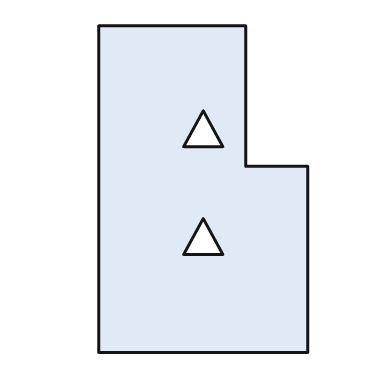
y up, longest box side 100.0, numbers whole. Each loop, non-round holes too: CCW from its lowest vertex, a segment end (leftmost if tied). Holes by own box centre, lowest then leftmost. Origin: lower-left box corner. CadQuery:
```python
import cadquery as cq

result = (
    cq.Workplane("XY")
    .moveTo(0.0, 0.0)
    .lineTo(64.0, 0.0)
    .lineTo(64.0, 57.0)
    .lineTo(45.0, 57.0)
    .lineTo(45.0, 100.0)
    .lineTo(0.0, 100.0)
    .close()
    .moveTo(26.0, 30.0)
    .lineTo(38.0, 30.0)
    .lineTo(32.0, 41.0)
    .close()
    .moveTo(26.0, 63.0)
    .lineTo(38.0, 63.0)
    .lineTo(32.0, 74.0)
    .close()
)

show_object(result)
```